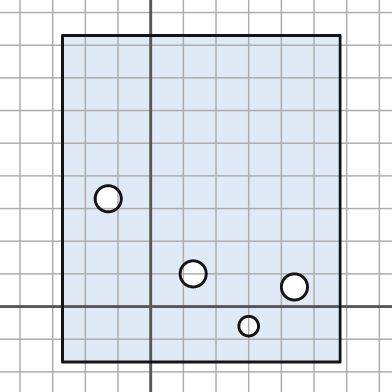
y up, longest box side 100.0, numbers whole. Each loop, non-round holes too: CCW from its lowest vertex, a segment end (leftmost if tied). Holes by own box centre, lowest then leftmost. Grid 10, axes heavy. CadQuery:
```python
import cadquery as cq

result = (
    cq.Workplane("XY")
    .moveTo(-27.0, -17.0)
    .lineTo(58.0, -17.0)
    .lineTo(58.0, 83.0)
    .lineTo(-27.0, 83.0)
    .close()
    .moveTo(30.0, -6.0)
    .circle(3.0)
    .moveTo(44.0, 6.0)
    .circle(4.0)
    .moveTo(13.0, 10.0)
    .circle(4.0)
    .moveTo(-13.0, 33.0)
    .circle(4.0)
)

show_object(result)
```